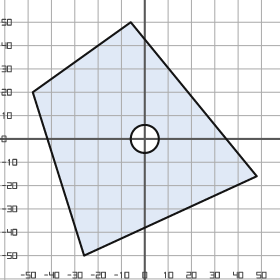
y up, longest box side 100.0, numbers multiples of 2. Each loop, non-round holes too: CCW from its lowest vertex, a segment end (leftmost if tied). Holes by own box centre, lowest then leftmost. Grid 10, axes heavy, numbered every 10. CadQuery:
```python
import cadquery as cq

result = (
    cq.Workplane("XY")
    .moveTo(-26.0, -50.0)
    .lineTo(48.0, -16.0)
    .lineTo(-6.0, 50.0)
    .lineTo(-48.0, 20.0)
    .close()
    .moveTo(0.0, 0.0)
    .circle(6.0)
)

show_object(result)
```